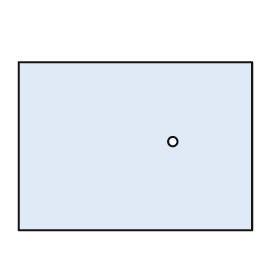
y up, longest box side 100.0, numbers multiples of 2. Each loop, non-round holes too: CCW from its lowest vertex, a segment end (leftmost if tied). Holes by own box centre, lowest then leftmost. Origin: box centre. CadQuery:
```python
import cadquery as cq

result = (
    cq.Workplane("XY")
    .moveTo(-50.0, -36.0)
    .lineTo(50.0, -36.0)
    .lineTo(50.0, 36.0)
    .lineTo(-50.0, 36.0)
    .close()
    .moveTo(16.0, 2.0)
    .circle(2.0)
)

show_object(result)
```